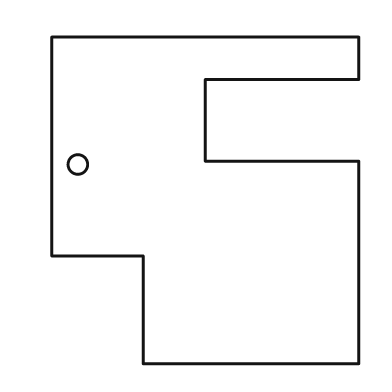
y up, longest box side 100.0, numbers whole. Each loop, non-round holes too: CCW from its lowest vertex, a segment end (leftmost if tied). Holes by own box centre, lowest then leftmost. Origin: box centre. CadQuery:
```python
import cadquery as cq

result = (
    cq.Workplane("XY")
    .moveTo(-19.0, -50.0)
    .lineTo(47.0, -50.0)
    .lineTo(47.0, 12.0)
    .lineTo(0.0, 12.0)
    .lineTo(0.0, 37.0)
    .lineTo(47.0, 37.0)
    .lineTo(47.0, 50.0)
    .lineTo(-47.0, 50.0)
    .lineTo(-47.0, -17.0)
    .lineTo(-19.0, -17.0)
    .close()
    .moveTo(-39.0, 11.0)
    .circle(3.0)
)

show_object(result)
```